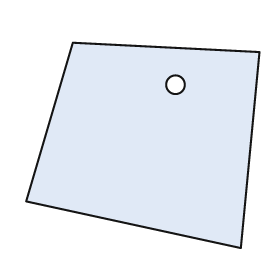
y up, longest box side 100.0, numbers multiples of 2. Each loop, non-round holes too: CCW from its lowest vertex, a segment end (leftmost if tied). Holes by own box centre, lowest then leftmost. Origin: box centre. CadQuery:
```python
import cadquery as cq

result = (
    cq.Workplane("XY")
    .moveTo(42.0, -44.0)
    .lineTo(50.0, 40.0)
    .lineTo(-30.0, 44.0)
    .lineTo(-50.0, -24.0)
    .close()
    .moveTo(14.0, 26.0)
    .circle(4.0)
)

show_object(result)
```